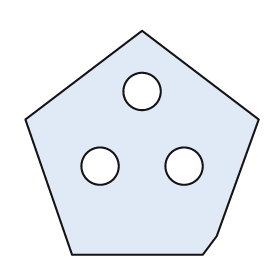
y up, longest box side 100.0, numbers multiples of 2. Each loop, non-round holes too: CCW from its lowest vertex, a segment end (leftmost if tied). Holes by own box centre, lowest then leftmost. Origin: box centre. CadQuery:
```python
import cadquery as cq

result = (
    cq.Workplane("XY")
    .moveTo(-30.0, -48.0)
    .lineTo(26.0, -48.0)
    .lineTo(32.0, -40.0)
    .lineTo(50.0, 10.0)
    .lineTo(0.0, 48.0)
    .lineTo(-50.0, 10.0)
    .close()
    .moveTo(-18.0, -10.0)
    .circle(8.0)
    .moveTo(18.0, -10.0)
    .circle(8.0)
    .moveTo(0.0, 22.0)
    .circle(8.0)
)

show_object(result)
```